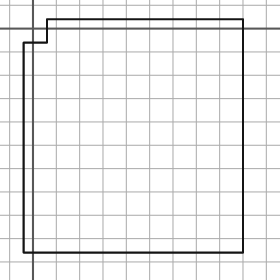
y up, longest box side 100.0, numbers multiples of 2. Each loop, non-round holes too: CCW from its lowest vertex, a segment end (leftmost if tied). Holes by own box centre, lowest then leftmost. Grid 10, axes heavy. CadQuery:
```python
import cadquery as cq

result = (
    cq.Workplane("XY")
    .moveTo(-4.0, -96.0)
    .lineTo(90.0, -96.0)
    .lineTo(90.0, 4.0)
    .lineTo(6.0, 4.0)
    .lineTo(6.0, -6.0)
    .lineTo(-4.0, -6.0)
    .close()
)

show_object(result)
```